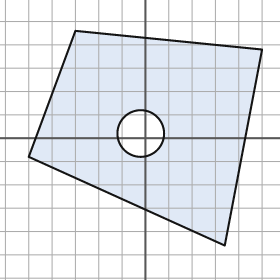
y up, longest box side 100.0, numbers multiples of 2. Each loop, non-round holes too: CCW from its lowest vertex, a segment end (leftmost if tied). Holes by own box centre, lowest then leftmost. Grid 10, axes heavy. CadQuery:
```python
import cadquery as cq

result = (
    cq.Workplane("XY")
    .moveTo(34.0, -46.0)
    .lineTo(50.0, 38.0)
    .lineTo(-30.0, 46.0)
    .lineTo(-50.0, -8.0)
    .close()
    .moveTo(-2.0, 2.0)
    .circle(10.0)
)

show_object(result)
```